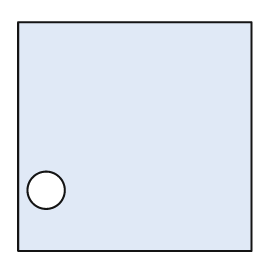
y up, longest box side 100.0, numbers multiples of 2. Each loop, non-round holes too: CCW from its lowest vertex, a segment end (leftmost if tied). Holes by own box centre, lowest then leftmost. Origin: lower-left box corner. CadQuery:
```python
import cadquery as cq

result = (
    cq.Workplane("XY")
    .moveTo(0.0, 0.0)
    .lineTo(100.0, 0.0)
    .lineTo(100.0, 98.0)
    .lineTo(0.0, 98.0)
    .close()
    .moveTo(12.0, 26.0)
    .circle(8.0)
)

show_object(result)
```